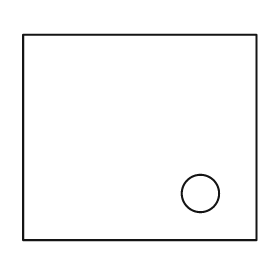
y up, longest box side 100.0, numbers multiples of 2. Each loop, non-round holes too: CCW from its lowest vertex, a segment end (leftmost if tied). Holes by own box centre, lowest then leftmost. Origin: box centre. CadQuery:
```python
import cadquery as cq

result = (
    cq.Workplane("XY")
    .moveTo(-50.0, -44.0)
    .lineTo(50.0, -44.0)
    .lineTo(50.0, 44.0)
    .lineTo(-50.0, 44.0)
    .close()
    .moveTo(26.0, -24.0)
    .circle(8.0)
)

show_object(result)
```